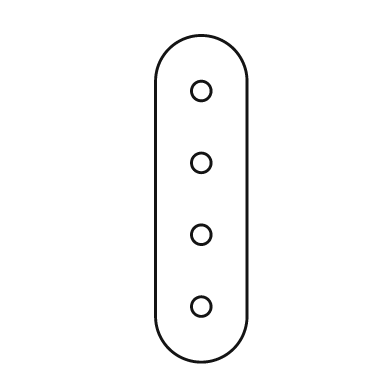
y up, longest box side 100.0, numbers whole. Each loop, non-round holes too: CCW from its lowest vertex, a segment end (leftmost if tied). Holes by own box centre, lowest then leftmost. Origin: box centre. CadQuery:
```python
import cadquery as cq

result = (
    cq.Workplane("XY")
    .moveTo(-14.0, -36.0)
    .threePointArc((0.0, -50.0), (14.0, -36.0))
    .lineTo(14.0, 36.0)
    .threePointArc((0.0, 50.0), (-14.0, 36.0))
    .close()
    .moveTo(0.0, -33.0)
    .circle(3.0)
    .moveTo(0.0, -11.0)
    .circle(3.0)
    .moveTo(0.0, 11.0)
    .circle(3.0)
    .moveTo(0.0, 33.0)
    .circle(3.0)
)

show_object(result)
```